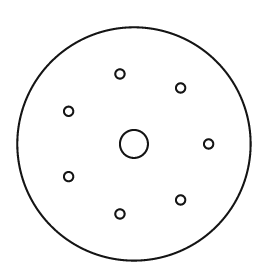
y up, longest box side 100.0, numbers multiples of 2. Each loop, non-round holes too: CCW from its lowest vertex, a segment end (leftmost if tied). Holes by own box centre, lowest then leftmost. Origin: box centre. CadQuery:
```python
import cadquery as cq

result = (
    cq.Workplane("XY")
    .moveTo(0.0, 0.0)
    .circle(50.0)
    .moveTo(-6.0, -30.0)
    .circle(2.0)
    .moveTo(20.0, -24.0)
    .circle(2.0)
    .moveTo(-28.0, -14.0)
    .circle(2.0)
    .moveTo(0.0, 0.0)
    .circle(6.0)
    .moveTo(32.0, 0.0)
    .circle(2.0)
    .moveTo(-28.0, 14.0)
    .circle(2.0)
    .moveTo(20.0, 24.0)
    .circle(2.0)
    .moveTo(-6.0, 30.0)
    .circle(2.0)
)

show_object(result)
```